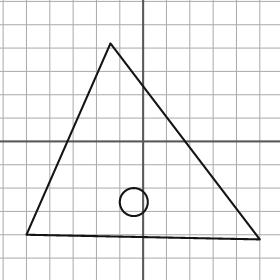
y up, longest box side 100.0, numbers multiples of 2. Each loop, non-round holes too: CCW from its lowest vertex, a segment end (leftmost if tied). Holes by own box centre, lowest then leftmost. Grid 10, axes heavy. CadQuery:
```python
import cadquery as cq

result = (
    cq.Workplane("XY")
    .moveTo(50.0, -42.0)
    .lineTo(-14.0, 42.0)
    .lineTo(-50.0, -40.0)
    .close()
    .moveTo(-4.0, -26.0)
    .circle(6.0)
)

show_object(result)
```